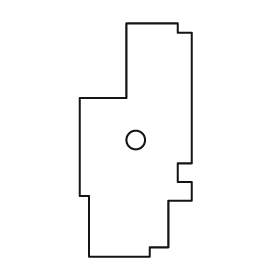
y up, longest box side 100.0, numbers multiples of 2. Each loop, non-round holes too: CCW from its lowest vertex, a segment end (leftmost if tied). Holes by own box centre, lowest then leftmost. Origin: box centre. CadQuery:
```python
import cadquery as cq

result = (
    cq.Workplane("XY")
    .moveTo(-20.0, -50.0)
    .lineTo(6.0, -50.0)
    .lineTo(6.0, -46.0)
    .lineTo(14.0, -46.0)
    .lineTo(14.0, -26.0)
    .lineTo(24.0, -26.0)
    .lineTo(24.0, -18.0)
    .lineTo(18.0, -18.0)
    .lineTo(18.0, -10.0)
    .lineTo(24.0, -10.0)
    .lineTo(24.0, 46.0)
    .lineTo(18.0, 46.0)
    .lineTo(18.0, 50.0)
    .lineTo(-4.0, 50.0)
    .lineTo(-4.0, 18.0)
    .lineTo(-24.0, 18.0)
    .lineTo(-24.0, -24.0)
    .lineTo(-20.0, -24.0)
    .close()
    .moveTo(0.0, 0.0)
    .circle(4.0)
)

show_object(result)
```